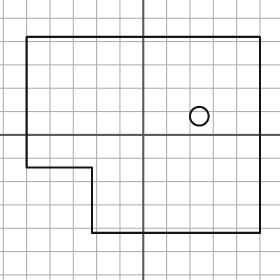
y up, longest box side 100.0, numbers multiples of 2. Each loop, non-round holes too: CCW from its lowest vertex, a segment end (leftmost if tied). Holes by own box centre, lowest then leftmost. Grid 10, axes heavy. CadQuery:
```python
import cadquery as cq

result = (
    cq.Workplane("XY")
    .moveTo(-22.0, -42.0)
    .lineTo(50.0, -42.0)
    .lineTo(50.0, 42.0)
    .lineTo(-50.0, 42.0)
    .lineTo(-50.0, -14.0)
    .lineTo(-22.0, -14.0)
    .close()
    .moveTo(24.0, 8.0)
    .circle(4.0)
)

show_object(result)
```